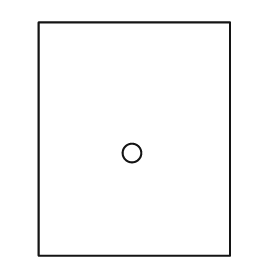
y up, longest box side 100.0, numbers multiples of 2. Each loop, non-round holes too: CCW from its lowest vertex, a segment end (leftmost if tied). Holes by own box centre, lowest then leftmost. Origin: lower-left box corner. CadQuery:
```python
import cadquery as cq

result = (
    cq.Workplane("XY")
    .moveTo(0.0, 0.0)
    .lineTo(82.0, 0.0)
    .lineTo(82.0, 100.0)
    .lineTo(0.0, 100.0)
    .close()
    .moveTo(40.0, 44.0)
    .circle(4.0)
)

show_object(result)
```